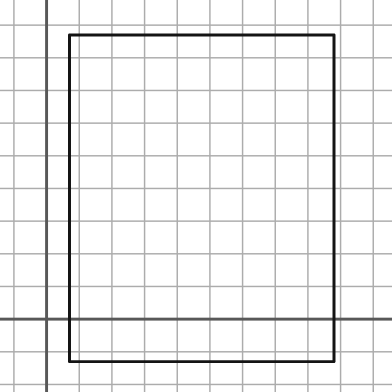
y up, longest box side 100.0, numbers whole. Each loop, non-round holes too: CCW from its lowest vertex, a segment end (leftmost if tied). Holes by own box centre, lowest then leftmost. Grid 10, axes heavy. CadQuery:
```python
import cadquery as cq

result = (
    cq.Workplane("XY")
    .moveTo(7.0, -13.0)
    .lineTo(88.0, -13.0)
    .lineTo(88.0, 87.0)
    .lineTo(7.0, 87.0)
    .close()
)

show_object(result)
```